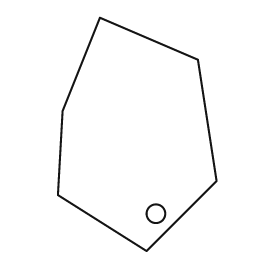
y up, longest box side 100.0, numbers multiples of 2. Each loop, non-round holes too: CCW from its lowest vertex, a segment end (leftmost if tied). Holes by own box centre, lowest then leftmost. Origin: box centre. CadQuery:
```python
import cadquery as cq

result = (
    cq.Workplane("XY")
    .moveTo(4.0, -50.0)
    .lineTo(34.0, -20.0)
    .lineTo(26.0, 32.0)
    .lineTo(-16.0, 50.0)
    .lineTo(-32.0, 10.0)
    .lineTo(-34.0, -26.0)
    .close()
    .moveTo(8.0, -34.0)
    .circle(4.0)
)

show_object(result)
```